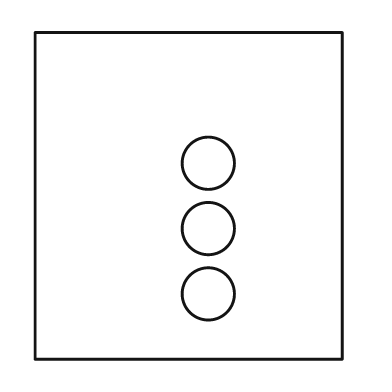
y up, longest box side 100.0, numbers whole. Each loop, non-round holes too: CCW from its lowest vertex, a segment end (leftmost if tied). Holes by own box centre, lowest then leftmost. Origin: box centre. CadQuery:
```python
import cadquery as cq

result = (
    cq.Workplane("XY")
    .moveTo(-47.0, -50.0)
    .lineTo(47.0, -50.0)
    .lineTo(47.0, 50.0)
    .lineTo(-47.0, 50.0)
    .close()
    .moveTo(6.0, -30.0)
    .circle(8.0)
    .moveTo(6.0, -10.0)
    .circle(8.0)
    .moveTo(6.0, 10.0)
    .circle(8.0)
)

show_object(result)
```